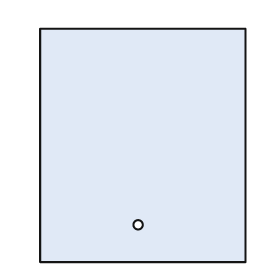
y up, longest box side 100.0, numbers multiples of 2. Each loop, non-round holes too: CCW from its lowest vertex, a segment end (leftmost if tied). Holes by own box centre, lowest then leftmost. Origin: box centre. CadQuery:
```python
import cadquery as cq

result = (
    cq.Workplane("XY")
    .moveTo(-44.0, -50.0)
    .lineTo(44.0, -50.0)
    .lineTo(44.0, 50.0)
    .lineTo(-44.0, 50.0)
    .close()
    .moveTo(-2.0, -34.0)
    .circle(2.0)
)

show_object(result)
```